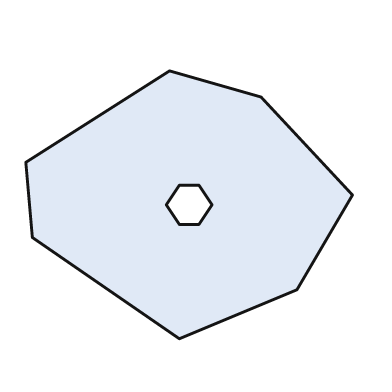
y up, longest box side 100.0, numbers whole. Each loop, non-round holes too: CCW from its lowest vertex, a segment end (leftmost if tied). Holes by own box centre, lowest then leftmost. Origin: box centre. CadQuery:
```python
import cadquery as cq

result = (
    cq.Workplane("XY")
    .moveTo(-3.0, -41.0)
    .lineTo(33.0, -26.0)
    .lineTo(50.0, 3.0)
    .lineTo(22.0, 33.0)
    .lineTo(-6.0, 41.0)
    .lineTo(-50.0, 13.0)
    .lineTo(-48.0, -10.0)
    .close()
    .moveTo(-3.0, -6.0)
    .lineTo(3.0, -6.0)
    .lineTo(7.0, 0.0)
    .lineTo(3.0, 6.0)
    .lineTo(-3.0, 6.0)
    .lineTo(-7.0, 0.0)
    .close()
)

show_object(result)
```